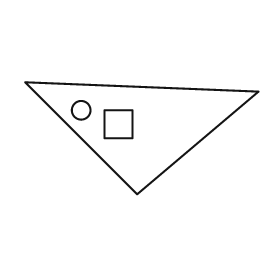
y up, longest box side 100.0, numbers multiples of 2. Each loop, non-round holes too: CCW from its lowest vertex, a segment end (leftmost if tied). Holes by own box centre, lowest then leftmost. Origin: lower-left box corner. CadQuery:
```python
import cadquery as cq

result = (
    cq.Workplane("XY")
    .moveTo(48.0, 0.0)
    .lineTo(100.0, 44.0)
    .lineTo(0.0, 48.0)
    .close()
    .moveTo(34.0, 24.0)
    .lineTo(46.0, 24.0)
    .lineTo(46.0, 36.0)
    .lineTo(34.0, 36.0)
    .close()
    .moveTo(24.0, 36.0)
    .circle(4.0)
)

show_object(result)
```